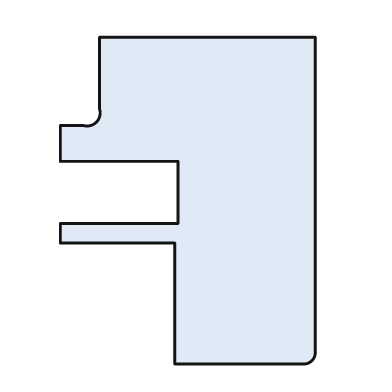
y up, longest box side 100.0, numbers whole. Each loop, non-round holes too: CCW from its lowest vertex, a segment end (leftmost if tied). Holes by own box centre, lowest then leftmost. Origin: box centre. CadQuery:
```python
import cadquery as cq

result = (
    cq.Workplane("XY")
    .moveTo(-4.0, -50.0)
    .lineTo(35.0, -50.0)
    .threePointArc((38.0, -49.0), (39.0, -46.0))
    .lineTo(39.0, 50.0)
    .lineTo(-27.0, 50.0)
    .lineTo(-27.0, 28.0)
    .threePointArc((-28.0, 24.0), (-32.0, 23.0))
    .lineTo(-39.0, 23.0)
    .lineTo(-39.0, 12.0)
    .lineTo(-3.0, 12.0)
    .lineTo(-3.0, -7.0)
    .lineTo(-39.0, -7.0)
    .lineTo(-39.0, -13.0)
    .lineTo(-4.0, -13.0)
    .close()
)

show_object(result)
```